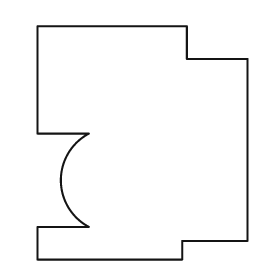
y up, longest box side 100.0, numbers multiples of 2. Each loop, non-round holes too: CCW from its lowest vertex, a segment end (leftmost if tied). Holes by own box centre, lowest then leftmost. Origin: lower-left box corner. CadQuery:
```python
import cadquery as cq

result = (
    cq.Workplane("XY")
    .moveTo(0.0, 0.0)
    .lineTo(62.0, 0.0)
    .lineTo(62.0, 8.0)
    .lineTo(90.0, 8.0)
    .lineTo(90.0, 86.0)
    .lineTo(64.0, 86.0)
    .lineTo(64.0, 100.0)
    .lineTo(0.0, 100.0)
    .lineTo(0.0, 54.0)
    .lineTo(22.0, 54.0)
    .threePointArc((10.0, 34.0), (22.0, 14.0))
    .lineTo(0.0, 14.0)
    .close()
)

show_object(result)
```